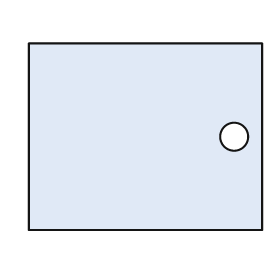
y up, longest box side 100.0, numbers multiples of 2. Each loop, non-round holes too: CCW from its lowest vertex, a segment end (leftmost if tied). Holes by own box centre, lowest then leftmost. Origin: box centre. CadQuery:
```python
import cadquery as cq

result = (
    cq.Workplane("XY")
    .moveTo(-50.0, -40.0)
    .lineTo(50.0, -40.0)
    .lineTo(50.0, 40.0)
    .lineTo(-50.0, 40.0)
    .close()
    .moveTo(38.0, 0.0)
    .circle(6.0)
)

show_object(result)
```